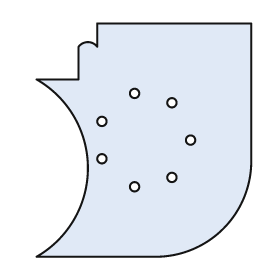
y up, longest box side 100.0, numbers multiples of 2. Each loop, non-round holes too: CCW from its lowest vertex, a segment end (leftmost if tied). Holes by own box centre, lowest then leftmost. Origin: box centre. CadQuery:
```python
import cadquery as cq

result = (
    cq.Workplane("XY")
    .moveTo(-46.0, -50.0)
    .lineTo(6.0, -50.0)
    .threePointArc((34.0, -38.0), (46.0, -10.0))
    .lineTo(46.0, 50.0)
    .lineTo(-20.0, 50.0)
    .lineTo(-20.0, 40.0)
    .threePointArc((-24.0, 42.0), (-28.0, 40.0))
    .lineTo(-28.0, 26.0)
    .lineTo(-46.0, 26.0)
    .threePointArc((-24.0, -12.0), (-46.0, -50.0))
    .close()
    .moveTo(-4.0, -20.0)
    .circle(2.0)
    .moveTo(12.0, -16.0)
    .circle(2.0)
    .moveTo(-18.0, -8.0)
    .circle(2.0)
    .moveTo(20.0, 0.0)
    .circle(2.0)
    .moveTo(-18.0, 8.0)
    .circle(2.0)
    .moveTo(12.0, 16.0)
    .circle(2.0)
    .moveTo(-4.0, 20.0)
    .circle(2.0)
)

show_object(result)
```